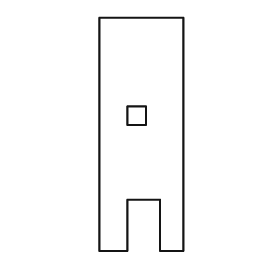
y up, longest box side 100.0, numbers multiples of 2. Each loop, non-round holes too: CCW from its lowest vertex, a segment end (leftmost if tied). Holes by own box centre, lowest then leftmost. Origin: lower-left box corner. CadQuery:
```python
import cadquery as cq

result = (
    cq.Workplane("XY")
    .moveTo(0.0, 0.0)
    .lineTo(12.0, 0.0)
    .lineTo(12.0, 22.0)
    .lineTo(26.0, 22.0)
    .lineTo(26.0, 0.0)
    .lineTo(36.0, 0.0)
    .lineTo(36.0, 100.0)
    .lineTo(0.0, 100.0)
    .close()
    .moveTo(12.0, 54.0)
    .lineTo(20.0, 54.0)
    .lineTo(20.0, 62.0)
    .lineTo(12.0, 62.0)
    .close()
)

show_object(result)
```